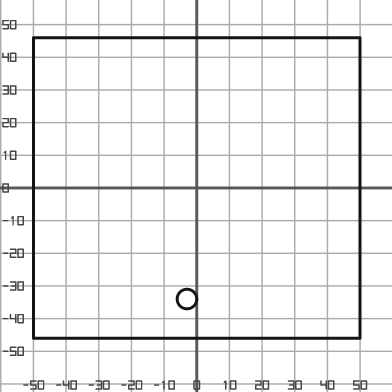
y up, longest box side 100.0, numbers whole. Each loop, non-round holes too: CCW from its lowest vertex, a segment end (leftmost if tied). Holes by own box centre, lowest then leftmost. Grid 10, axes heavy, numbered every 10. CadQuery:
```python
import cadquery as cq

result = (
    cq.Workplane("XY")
    .moveTo(-50.0, -46.0)
    .lineTo(50.0, -46.0)
    .lineTo(50.0, 46.0)
    .lineTo(-50.0, 46.0)
    .close()
    .moveTo(-3.0, -34.0)
    .circle(3.0)
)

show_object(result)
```